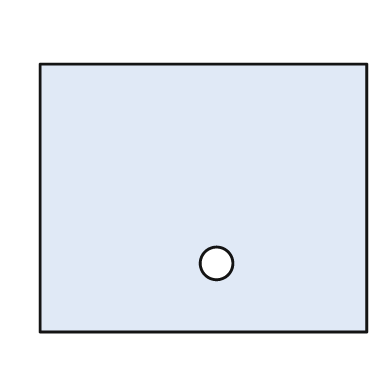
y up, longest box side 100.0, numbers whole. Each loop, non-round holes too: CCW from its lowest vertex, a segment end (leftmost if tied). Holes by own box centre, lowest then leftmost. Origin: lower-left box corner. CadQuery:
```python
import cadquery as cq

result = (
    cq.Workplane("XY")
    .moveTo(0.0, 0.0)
    .lineTo(100.0, 0.0)
    .lineTo(100.0, 82.0)
    .lineTo(0.0, 82.0)
    .close()
    .moveTo(54.0, 21.0)
    .circle(5.0)
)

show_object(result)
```